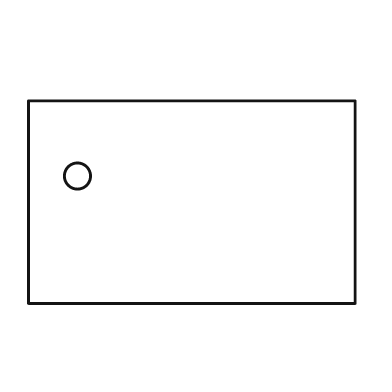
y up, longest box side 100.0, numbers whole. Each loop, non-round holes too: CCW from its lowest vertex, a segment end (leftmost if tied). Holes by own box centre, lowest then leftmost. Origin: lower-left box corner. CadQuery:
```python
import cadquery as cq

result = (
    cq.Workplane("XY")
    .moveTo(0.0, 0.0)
    .lineTo(100.0, 0.0)
    .lineTo(100.0, 62.0)
    .lineTo(0.0, 62.0)
    .close()
    .moveTo(15.0, 39.0)
    .circle(4.0)
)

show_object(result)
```